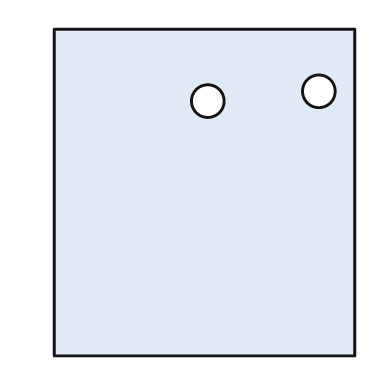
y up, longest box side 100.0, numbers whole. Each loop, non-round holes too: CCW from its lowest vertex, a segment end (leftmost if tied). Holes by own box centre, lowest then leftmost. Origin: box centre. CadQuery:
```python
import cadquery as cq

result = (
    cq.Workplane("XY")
    .moveTo(-46.0, -50.0)
    .lineTo(46.0, -50.0)
    .lineTo(46.0, 50.0)
    .lineTo(-46.0, 50.0)
    .close()
    .moveTo(1.0, 28.0)
    .circle(5.0)
    .moveTo(35.0, 31.0)
    .circle(5.0)
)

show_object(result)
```